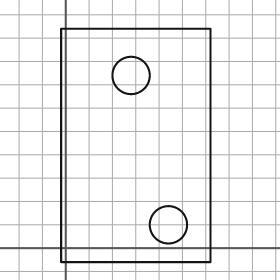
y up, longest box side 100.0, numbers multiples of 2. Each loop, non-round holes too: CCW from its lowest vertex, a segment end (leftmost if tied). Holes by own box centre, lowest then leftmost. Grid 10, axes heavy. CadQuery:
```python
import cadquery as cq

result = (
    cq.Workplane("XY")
    .moveTo(-2.0, -6.0)
    .lineTo(62.0, -6.0)
    .lineTo(62.0, 94.0)
    .lineTo(-2.0, 94.0)
    .close()
    .moveTo(44.0, 10.0)
    .circle(8.0)
    .moveTo(28.0, 74.0)
    .circle(8.0)
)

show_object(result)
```